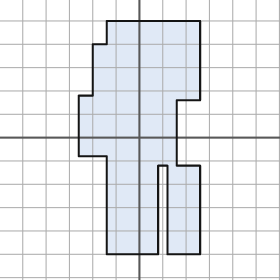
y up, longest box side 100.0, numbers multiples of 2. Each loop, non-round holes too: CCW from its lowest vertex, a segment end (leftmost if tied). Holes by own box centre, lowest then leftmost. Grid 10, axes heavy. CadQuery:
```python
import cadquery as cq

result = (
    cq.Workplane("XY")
    .moveTo(-14.0, -50.0)
    .lineTo(8.0, -50.0)
    .lineTo(8.0, -12.0)
    .lineTo(12.0, -12.0)
    .lineTo(12.0, -50.0)
    .lineTo(26.0, -50.0)
    .lineTo(26.0, -12.0)
    .lineTo(16.0, -12.0)
    .lineTo(16.0, 16.0)
    .lineTo(26.0, 16.0)
    .lineTo(26.0, 50.0)
    .lineTo(-14.0, 50.0)
    .lineTo(-14.0, 40.0)
    .lineTo(-20.0, 40.0)
    .lineTo(-20.0, 18.0)
    .lineTo(-26.0, 18.0)
    .lineTo(-26.0, -8.0)
    .lineTo(-14.0, -8.0)
    .close()
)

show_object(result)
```